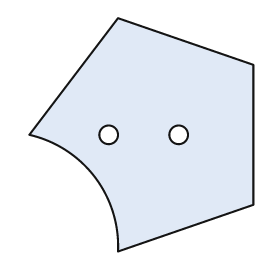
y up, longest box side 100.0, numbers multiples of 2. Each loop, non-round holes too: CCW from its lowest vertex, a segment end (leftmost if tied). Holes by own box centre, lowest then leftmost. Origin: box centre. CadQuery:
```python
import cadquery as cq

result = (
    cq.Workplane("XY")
    .moveTo(-10.0, -50.0)
    .lineTo(48.0, -30.0)
    .lineTo(48.0, 30.0)
    .lineTo(-10.0, 50.0)
    .lineTo(-48.0, 0.0)
    .threePointArc((-20.0, -18.0), (-10.0, -50.0))
    .close()
    .moveTo(-14.0, 0.0)
    .circle(4.0)
    .moveTo(16.0, 0.0)
    .circle(4.0)
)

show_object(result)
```